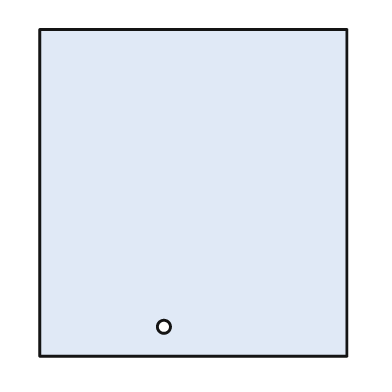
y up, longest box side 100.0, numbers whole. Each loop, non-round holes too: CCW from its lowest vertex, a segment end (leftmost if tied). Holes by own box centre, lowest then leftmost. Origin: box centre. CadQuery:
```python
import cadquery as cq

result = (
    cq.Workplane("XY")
    .moveTo(-47.0, -50.0)
    .lineTo(47.0, -50.0)
    .lineTo(47.0, 50.0)
    .lineTo(-47.0, 50.0)
    .close()
    .moveTo(-9.0, -41.0)
    .circle(2.0)
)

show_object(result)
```